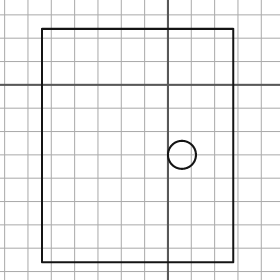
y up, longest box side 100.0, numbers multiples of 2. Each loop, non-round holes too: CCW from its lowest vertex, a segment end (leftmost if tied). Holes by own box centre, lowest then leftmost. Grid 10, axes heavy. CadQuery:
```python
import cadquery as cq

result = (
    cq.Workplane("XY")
    .moveTo(-54.0, -76.0)
    .lineTo(28.0, -76.0)
    .lineTo(28.0, 24.0)
    .lineTo(-54.0, 24.0)
    .close()
    .moveTo(6.0, -30.0)
    .circle(6.0)
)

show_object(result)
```